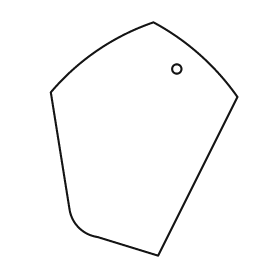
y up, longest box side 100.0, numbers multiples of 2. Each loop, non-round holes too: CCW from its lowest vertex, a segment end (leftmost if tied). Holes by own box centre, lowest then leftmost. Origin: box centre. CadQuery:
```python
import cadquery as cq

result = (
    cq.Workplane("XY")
    .moveTo(6.0, -50.0)
    .lineTo(40.0, 18.0)
    .threePointArc((24.0, 36.0), (4.0, 50.0))
    .threePointArc((-20.0, 38.0), (-40.0, 20.0))
    .lineTo(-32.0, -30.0)
    .threePointArc((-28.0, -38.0), (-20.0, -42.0))
    .close()
    .moveTo(14.0, 30.0)
    .circle(2.0)
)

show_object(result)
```